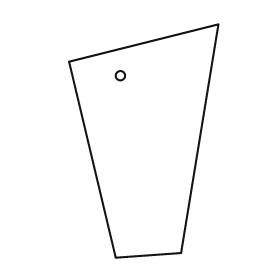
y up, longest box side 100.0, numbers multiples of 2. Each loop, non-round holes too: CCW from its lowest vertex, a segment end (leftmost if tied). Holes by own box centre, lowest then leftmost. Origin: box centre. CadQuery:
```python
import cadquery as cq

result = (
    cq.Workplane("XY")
    .moveTo(-12.0, -50.0)
    .lineTo(16.0, -48.0)
    .lineTo(32.0, 50.0)
    .lineTo(-32.0, 34.0)
    .close()
    .moveTo(-10.0, 28.0)
    .circle(2.0)
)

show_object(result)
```